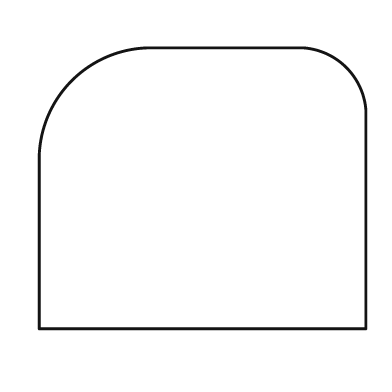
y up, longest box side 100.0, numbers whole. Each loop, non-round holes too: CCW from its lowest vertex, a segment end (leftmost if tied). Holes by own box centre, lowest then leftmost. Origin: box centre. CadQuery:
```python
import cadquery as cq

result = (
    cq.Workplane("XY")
    .moveTo(-50.0, -43.0)
    .lineTo(50.0, -43.0)
    .lineTo(50.0, 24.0)
    .threePointArc((44.0, 37.0), (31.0, 43.0))
    .lineTo(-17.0, 43.0)
    .threePointArc((-40.0, 33.0), (-50.0, 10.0))
    .close()
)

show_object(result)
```